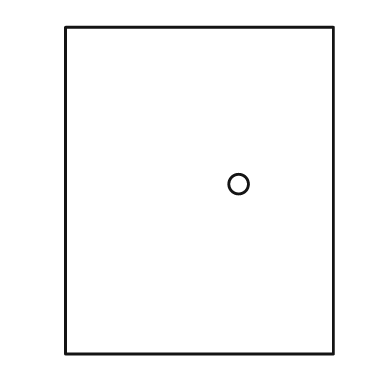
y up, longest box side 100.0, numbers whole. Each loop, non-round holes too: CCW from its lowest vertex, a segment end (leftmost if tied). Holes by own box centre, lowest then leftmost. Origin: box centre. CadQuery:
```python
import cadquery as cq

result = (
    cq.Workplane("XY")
    .moveTo(-41.0, -50.0)
    .lineTo(41.0, -50.0)
    .lineTo(41.0, 50.0)
    .lineTo(-41.0, 50.0)
    .close()
    .moveTo(12.0, 2.0)
    .circle(3.0)
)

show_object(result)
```